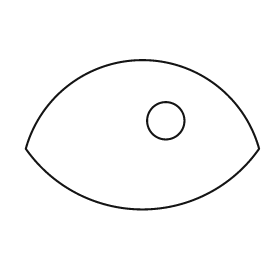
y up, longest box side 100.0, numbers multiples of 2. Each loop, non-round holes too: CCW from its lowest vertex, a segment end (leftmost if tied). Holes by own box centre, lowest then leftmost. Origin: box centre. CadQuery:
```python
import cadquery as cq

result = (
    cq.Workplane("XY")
    .moveTo(-50.0, -6.0)
    .threePointArc((0.0, -32.0), (50.0, -6.0))
    .threePointArc((0.0, 32.0), (-50.0, -6.0))
    .close()
    .moveTo(10.0, 6.0)
    .circle(8.0)
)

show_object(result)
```